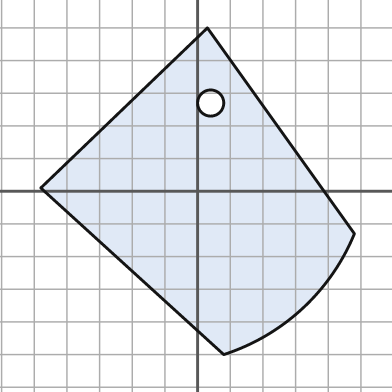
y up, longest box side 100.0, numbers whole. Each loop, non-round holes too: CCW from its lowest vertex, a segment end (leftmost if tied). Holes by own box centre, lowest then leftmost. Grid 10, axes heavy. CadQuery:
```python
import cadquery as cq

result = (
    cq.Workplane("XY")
    .moveTo(8.0, -50.0)
    .threePointArc((32.0, -36.0), (48.0, -13.0))
    .lineTo(3.0, 50.0)
    .lineTo(-48.0, 1.0)
    .close()
    .moveTo(4.0, 27.0)
    .circle(4.0)
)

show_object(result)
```